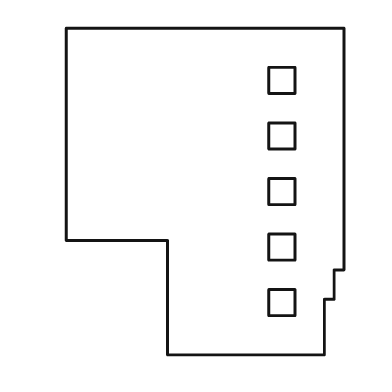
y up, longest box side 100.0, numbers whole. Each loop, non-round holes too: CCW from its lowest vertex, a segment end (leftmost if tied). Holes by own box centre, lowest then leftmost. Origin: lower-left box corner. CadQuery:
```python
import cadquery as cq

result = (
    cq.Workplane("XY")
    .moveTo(31.0, 0.0)
    .lineTo(79.0, 0.0)
    .lineTo(79.0, 17.0)
    .lineTo(82.0, 17.0)
    .lineTo(82.0, 26.0)
    .lineTo(85.0, 26.0)
    .lineTo(85.0, 100.0)
    .lineTo(0.0, 100.0)
    .lineTo(0.0, 35.0)
    .lineTo(31.0, 35.0)
    .close()
    .moveTo(62.0, 12.0)
    .lineTo(70.0, 12.0)
    .lineTo(70.0, 20.0)
    .lineTo(62.0, 20.0)
    .close()
    .moveTo(62.0, 29.0)
    .lineTo(70.0, 29.0)
    .lineTo(70.0, 37.0)
    .lineTo(62.0, 37.0)
    .close()
    .moveTo(62.0, 46.0)
    .lineTo(70.0, 46.0)
    .lineTo(70.0, 54.0)
    .lineTo(62.0, 54.0)
    .close()
    .moveTo(62.0, 63.0)
    .lineTo(70.0, 63.0)
    .lineTo(70.0, 71.0)
    .lineTo(62.0, 71.0)
    .close()
    .moveTo(62.0, 80.0)
    .lineTo(70.0, 80.0)
    .lineTo(70.0, 88.0)
    .lineTo(62.0, 88.0)
    .close()
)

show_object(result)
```